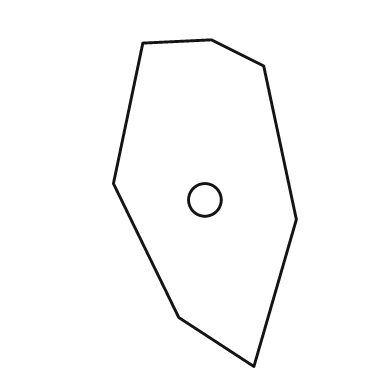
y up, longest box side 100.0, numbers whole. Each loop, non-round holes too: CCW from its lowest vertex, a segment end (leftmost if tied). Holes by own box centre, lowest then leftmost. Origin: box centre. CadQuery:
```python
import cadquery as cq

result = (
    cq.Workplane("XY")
    .moveTo(15.0, -50.0)
    .lineTo(28.0, -5.0)
    .lineTo(18.0, 42.0)
    .lineTo(2.0, 50.0)
    .lineTo(-19.0, 49.0)
    .lineTo(-28.0, 6.0)
    .lineTo(-8.0, -35.0)
    .close()
    .moveTo(0.0, 1.0)
    .circle(5.0)
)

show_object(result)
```